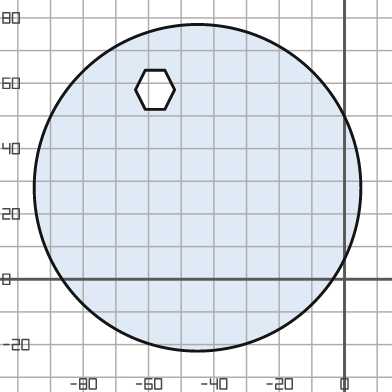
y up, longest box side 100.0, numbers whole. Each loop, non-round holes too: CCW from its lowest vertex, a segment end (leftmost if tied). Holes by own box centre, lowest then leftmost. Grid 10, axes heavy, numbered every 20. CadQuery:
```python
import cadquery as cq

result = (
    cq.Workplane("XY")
    .moveTo(-45.0, 28.0)
    .circle(50.0)
    .moveTo(-61.0, 52.0)
    .lineTo(-55.0, 52.0)
    .lineTo(-52.0, 58.0)
    .lineTo(-55.0, 64.0)
    .lineTo(-61.0, 64.0)
    .lineTo(-64.0, 58.0)
    .close()
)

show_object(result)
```